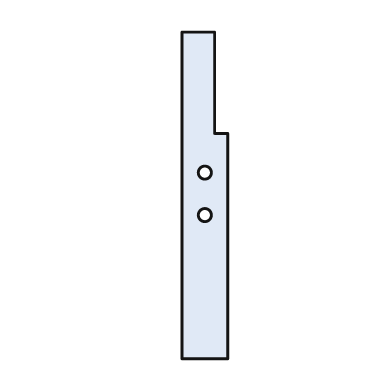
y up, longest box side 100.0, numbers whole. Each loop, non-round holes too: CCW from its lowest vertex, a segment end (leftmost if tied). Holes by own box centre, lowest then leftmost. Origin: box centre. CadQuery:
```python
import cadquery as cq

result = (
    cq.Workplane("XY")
    .moveTo(-7.0, -50.0)
    .lineTo(7.0, -50.0)
    .lineTo(7.0, 19.0)
    .lineTo(3.0, 19.0)
    .lineTo(3.0, 50.0)
    .lineTo(-7.0, 50.0)
    .close()
    .moveTo(0.0, -6.0)
    .circle(2.0)
    .moveTo(0.0, 7.0)
    .circle(2.0)
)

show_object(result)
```